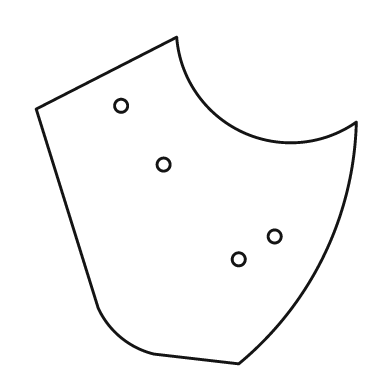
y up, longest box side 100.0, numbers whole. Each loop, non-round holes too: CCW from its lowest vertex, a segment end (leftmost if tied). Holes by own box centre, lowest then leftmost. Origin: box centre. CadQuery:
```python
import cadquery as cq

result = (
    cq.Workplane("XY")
    .moveTo(13.0, -50.0)
    .threePointArc((39.0, -17.0), (49.0, 24.0))
    .threePointArc((14.0, 21.0), (-6.0, 50.0))
    .lineTo(-49.0, 28.0)
    .lineTo(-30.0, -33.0)
    .threePointArc((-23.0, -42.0), (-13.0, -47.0))
    .close()
    .moveTo(13.0, -18.0)
    .circle(2.0)
    .moveTo(24.0, -11.0)
    .circle(2.0)
    .moveTo(-10.0, 11.0)
    .circle(2.0)
    .moveTo(-23.0, 29.0)
    .circle(2.0)
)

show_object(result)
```